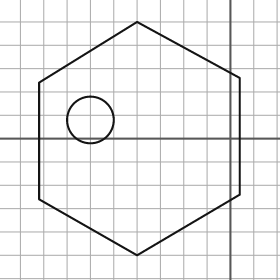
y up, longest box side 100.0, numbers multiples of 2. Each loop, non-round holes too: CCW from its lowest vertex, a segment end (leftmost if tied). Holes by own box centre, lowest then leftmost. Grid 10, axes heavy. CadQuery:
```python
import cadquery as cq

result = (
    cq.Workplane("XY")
    .moveTo(-40.0, -50.0)
    .lineTo(4.0, -24.0)
    .lineTo(4.0, 26.0)
    .lineTo(-40.0, 50.0)
    .lineTo(-82.0, 24.0)
    .lineTo(-82.0, -26.0)
    .close()
    .moveTo(-60.0, 8.0)
    .circle(10.0)
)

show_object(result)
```